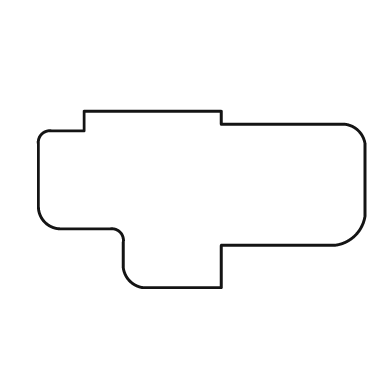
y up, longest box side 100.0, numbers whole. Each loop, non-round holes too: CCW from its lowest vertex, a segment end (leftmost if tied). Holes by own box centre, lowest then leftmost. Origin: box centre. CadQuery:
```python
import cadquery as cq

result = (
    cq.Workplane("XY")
    .moveTo(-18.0, -27.0)
    .lineTo(6.0, -27.0)
    .lineTo(6.0, -14.0)
    .lineTo(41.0, -14.0)
    .threePointArc((47.0, -11.0), (50.0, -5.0))
    .lineTo(50.0, 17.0)
    .threePointArc((48.0, 21.0), (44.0, 23.0))
    .lineTo(6.0, 23.0)
    .lineTo(6.0, 27.0)
    .lineTo(-36.0, 27.0)
    .lineTo(-36.0, 21.0)
    .lineTo(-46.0, 21.0)
    .threePointArc((-49.0, 20.0), (-50.0, 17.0))
    .lineTo(-50.0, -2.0)
    .threePointArc((-48.0, -7.0), (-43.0, -9.0))
    .lineTo(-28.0, -9.0)
    .threePointArc((-25.0, -10.0), (-24.0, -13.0))
    .lineTo(-24.0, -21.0)
    .threePointArc((-22.0, -25.0), (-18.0, -27.0))
    .close()
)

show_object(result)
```